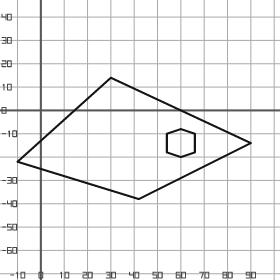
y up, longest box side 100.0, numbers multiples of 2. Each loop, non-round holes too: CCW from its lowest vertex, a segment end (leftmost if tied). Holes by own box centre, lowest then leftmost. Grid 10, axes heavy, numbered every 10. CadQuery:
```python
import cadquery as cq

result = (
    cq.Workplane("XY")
    .moveTo(42.0, -38.0)
    .lineTo(90.0, -14.0)
    .lineTo(30.0, 14.0)
    .lineTo(-10.0, -22.0)
    .close()
    .moveTo(60.0, -20.0)
    .lineTo(66.0, -18.0)
    .lineTo(66.0, -10.0)
    .lineTo(60.0, -8.0)
    .lineTo(54.0, -10.0)
    .lineTo(54.0, -18.0)
    .close()
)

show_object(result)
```